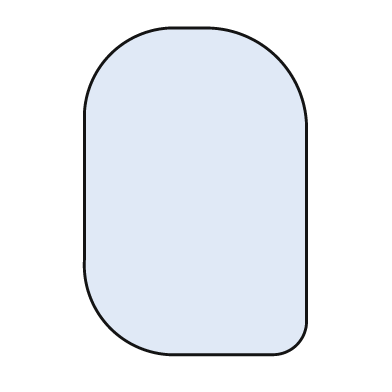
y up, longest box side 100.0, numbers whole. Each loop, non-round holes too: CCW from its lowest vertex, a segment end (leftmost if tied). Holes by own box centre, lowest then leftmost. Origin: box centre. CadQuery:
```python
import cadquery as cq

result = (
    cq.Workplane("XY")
    .moveTo(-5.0, -50.0)
    .lineTo(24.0, -50.0)
    .threePointArc((31.0, -47.0), (34.0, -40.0))
    .lineTo(34.0, 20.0)
    .threePointArc((25.0, 41.0), (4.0, 50.0))
    .lineTo(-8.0, 50.0)
    .threePointArc((-26.0, 42.0), (-34.0, 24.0))
    .lineTo(-34.0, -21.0)
    .threePointArc((-26.0, -42.0), (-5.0, -50.0))
    .close()
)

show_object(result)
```